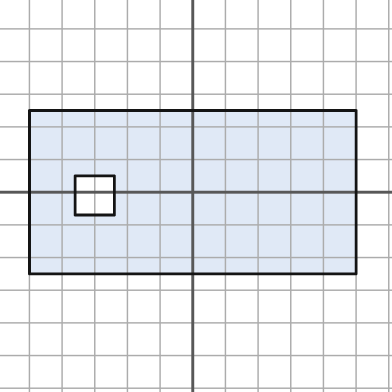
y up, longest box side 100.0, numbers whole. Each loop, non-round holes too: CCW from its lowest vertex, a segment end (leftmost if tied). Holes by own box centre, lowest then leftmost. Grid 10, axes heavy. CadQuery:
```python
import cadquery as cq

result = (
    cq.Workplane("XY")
    .moveTo(-50.0, -25.0)
    .lineTo(50.0, -25.0)
    .lineTo(50.0, 25.0)
    .lineTo(-50.0, 25.0)
    .close()
    .moveTo(-36.0, -7.0)
    .lineTo(-24.0, -7.0)
    .lineTo(-24.0, 5.0)
    .lineTo(-36.0, 5.0)
    .close()
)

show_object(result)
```